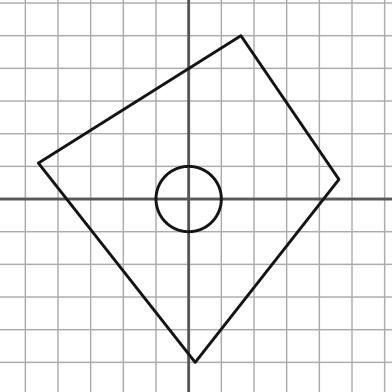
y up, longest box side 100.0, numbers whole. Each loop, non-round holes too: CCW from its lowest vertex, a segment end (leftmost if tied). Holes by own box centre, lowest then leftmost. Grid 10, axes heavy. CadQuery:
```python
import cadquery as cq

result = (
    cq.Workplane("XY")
    .moveTo(2.0, -50.0)
    .lineTo(46.0, 6.0)
    .lineTo(16.0, 50.0)
    .lineTo(-46.0, 11.0)
    .close()
    .moveTo(0.0, 0.0)
    .circle(10.0)
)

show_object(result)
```